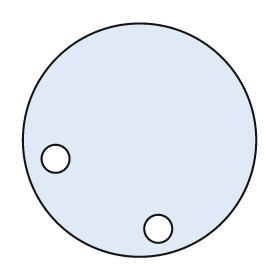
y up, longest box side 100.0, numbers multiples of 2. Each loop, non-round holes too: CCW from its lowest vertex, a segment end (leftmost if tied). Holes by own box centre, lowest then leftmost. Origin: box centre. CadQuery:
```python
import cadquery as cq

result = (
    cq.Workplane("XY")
    .moveTo(0.0, 0.0)
    .circle(50.0)
    .moveTo(8.0, -38.0)
    .circle(6.0)
    .moveTo(-36.0, -8.0)
    .circle(6.0)
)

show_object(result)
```